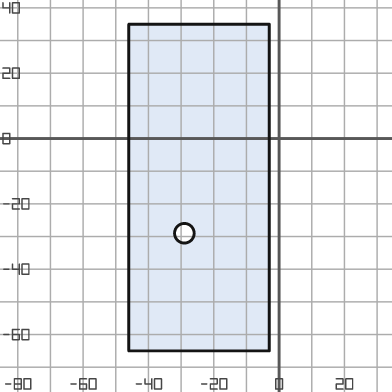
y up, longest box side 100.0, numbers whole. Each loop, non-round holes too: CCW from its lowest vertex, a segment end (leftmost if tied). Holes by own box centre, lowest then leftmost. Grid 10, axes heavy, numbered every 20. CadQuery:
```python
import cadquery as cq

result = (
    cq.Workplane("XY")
    .moveTo(-46.0, -65.0)
    .lineTo(-3.0, -65.0)
    .lineTo(-3.0, 35.0)
    .lineTo(-46.0, 35.0)
    .close()
    .moveTo(-29.0, -29.0)
    .circle(3.0)
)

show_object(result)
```